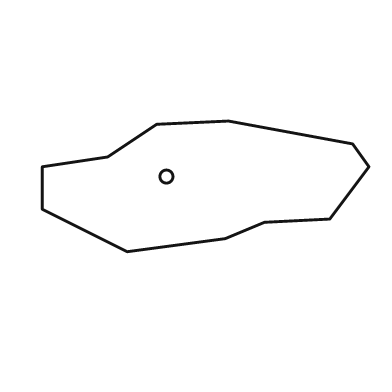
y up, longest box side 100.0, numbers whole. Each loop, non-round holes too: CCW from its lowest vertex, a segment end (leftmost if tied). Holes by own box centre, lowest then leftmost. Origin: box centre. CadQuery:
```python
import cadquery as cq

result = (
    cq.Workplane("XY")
    .moveTo(-24.0, -20.0)
    .lineTo(6.0, -16.0)
    .lineTo(18.0, -11.0)
    .lineTo(38.0, -10.0)
    .lineTo(50.0, 6.0)
    .lineTo(45.0, 13.0)
    .lineTo(7.0, 20.0)
    .lineTo(-15.0, 19.0)
    .lineTo(-30.0, 9.0)
    .lineTo(-50.0, 6.0)
    .lineTo(-50.0, -7.0)
    .close()
    .moveTo(-12.0, 3.0)
    .circle(2.0)
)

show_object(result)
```